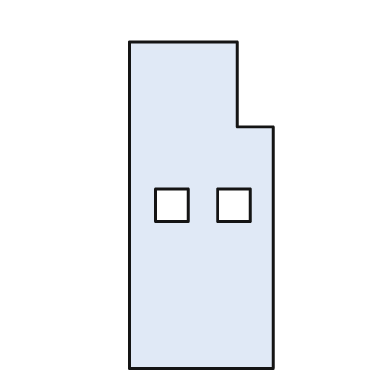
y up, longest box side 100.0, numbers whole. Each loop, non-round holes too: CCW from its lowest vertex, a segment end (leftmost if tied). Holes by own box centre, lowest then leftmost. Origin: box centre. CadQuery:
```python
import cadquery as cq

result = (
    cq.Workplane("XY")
    .moveTo(-22.0, -50.0)
    .lineTo(22.0, -50.0)
    .lineTo(22.0, 24.0)
    .lineTo(11.0, 24.0)
    .lineTo(11.0, 50.0)
    .lineTo(-22.0, 50.0)
    .close()
    .moveTo(-14.0, -5.0)
    .lineTo(-4.0, -5.0)
    .lineTo(-4.0, 5.0)
    .lineTo(-14.0, 5.0)
    .close()
    .moveTo(5.0, -5.0)
    .lineTo(15.0, -5.0)
    .lineTo(15.0, 5.0)
    .lineTo(5.0, 5.0)
    .close()
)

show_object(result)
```